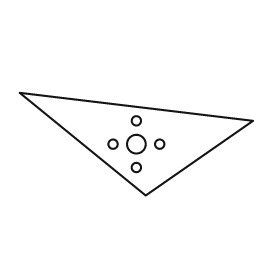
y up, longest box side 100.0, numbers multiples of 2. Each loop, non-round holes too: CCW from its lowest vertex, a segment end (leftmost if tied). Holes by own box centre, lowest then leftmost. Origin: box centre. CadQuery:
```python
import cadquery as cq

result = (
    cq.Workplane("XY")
    .moveTo(4.0, -22.0)
    .lineTo(50.0, 10.0)
    .lineTo(-50.0, 22.0)
    .close()
    .moveTo(0.0, -10.0)
    .circle(2.0)
    .moveTo(-10.0, 0.0)
    .circle(2.0)
    .moveTo(0.0, 0.0)
    .circle(4.0)
    .moveTo(10.0, 0.0)
    .circle(2.0)
    .moveTo(0.0, 10.0)
    .circle(2.0)
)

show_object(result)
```